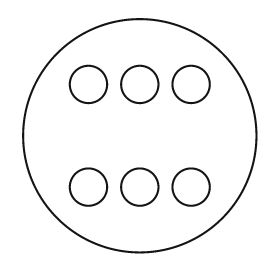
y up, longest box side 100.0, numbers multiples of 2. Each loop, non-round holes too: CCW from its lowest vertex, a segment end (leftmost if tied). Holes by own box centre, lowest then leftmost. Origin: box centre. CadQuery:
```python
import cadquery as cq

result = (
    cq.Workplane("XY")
    .moveTo(0.0, 0.0)
    .circle(50.0)
    .moveTo(-22.0, -22.0)
    .circle(8.0)
    .moveTo(0.0, -22.0)
    .circle(8.0)
    .moveTo(22.0, -22.0)
    .circle(8.0)
    .moveTo(-22.0, 22.0)
    .circle(8.0)
    .moveTo(0.0, 22.0)
    .circle(8.0)
    .moveTo(22.0, 22.0)
    .circle(8.0)
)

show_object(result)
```